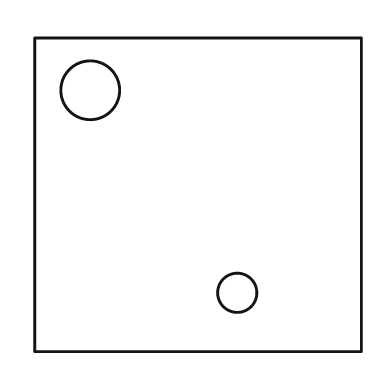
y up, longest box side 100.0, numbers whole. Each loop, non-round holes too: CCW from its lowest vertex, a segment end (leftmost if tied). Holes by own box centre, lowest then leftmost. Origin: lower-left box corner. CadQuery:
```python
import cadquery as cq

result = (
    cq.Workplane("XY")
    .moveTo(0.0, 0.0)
    .lineTo(100.0, 0.0)
    .lineTo(100.0, 96.0)
    .lineTo(0.0, 96.0)
    .close()
    .moveTo(62.0, 18.0)
    .circle(6.0)
    .moveTo(17.0, 80.0)
    .circle(9.0)
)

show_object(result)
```